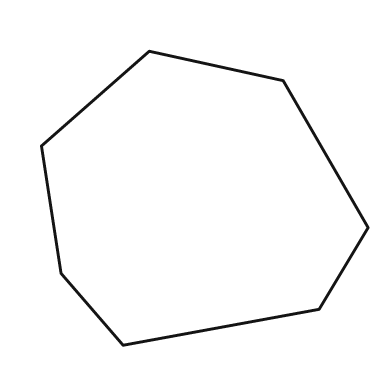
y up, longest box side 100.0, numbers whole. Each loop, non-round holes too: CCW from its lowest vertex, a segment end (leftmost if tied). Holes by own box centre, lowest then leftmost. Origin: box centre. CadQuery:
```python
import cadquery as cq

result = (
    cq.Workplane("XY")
    .moveTo(-25.0, -45.0)
    .lineTo(35.0, -34.0)
    .lineTo(50.0, -9.0)
    .lineTo(24.0, 36.0)
    .lineTo(-17.0, 45.0)
    .lineTo(-50.0, 16.0)
    .lineTo(-44.0, -23.0)
    .close()
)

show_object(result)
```